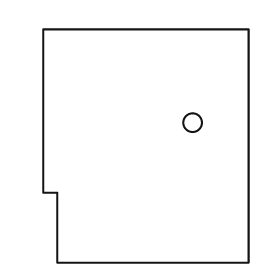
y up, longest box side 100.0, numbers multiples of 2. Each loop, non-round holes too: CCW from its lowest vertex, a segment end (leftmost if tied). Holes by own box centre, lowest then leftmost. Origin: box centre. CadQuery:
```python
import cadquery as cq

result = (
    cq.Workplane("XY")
    .moveTo(-38.0, -50.0)
    .lineTo(44.0, -50.0)
    .lineTo(44.0, 50.0)
    .lineTo(-44.0, 50.0)
    .lineTo(-44.0, -20.0)
    .lineTo(-38.0, -20.0)
    .close()
    .moveTo(20.0, 10.0)
    .circle(4.0)
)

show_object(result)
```